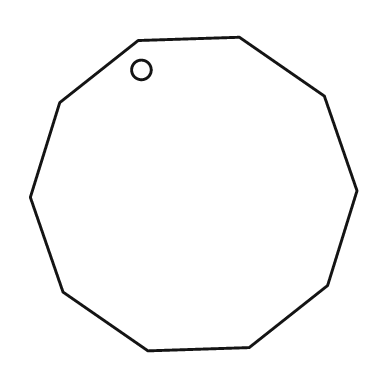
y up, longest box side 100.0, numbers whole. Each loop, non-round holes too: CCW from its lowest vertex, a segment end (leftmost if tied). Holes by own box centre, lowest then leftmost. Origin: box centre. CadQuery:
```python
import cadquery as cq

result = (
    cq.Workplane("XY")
    .moveTo(-14.0, -48.0)
    .lineTo(17.0, -47.0)
    .lineTo(41.0, -28.0)
    .lineTo(50.0, 1.0)
    .lineTo(40.0, 30.0)
    .lineTo(14.0, 48.0)
    .lineTo(-17.0, 47.0)
    .lineTo(-41.0, 28.0)
    .lineTo(-50.0, -1.0)
    .lineTo(-40.0, -30.0)
    .close()
    .moveTo(-16.0, 38.0)
    .circle(3.0)
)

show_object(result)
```